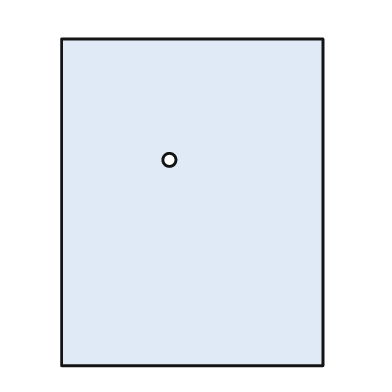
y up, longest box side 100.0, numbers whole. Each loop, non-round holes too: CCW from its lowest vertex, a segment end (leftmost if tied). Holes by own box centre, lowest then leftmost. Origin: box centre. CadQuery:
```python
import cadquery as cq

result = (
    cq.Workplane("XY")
    .moveTo(-40.0, -50.0)
    .lineTo(40.0, -50.0)
    .lineTo(40.0, 50.0)
    .lineTo(-40.0, 50.0)
    .close()
    .moveTo(-7.0, 13.0)
    .circle(2.0)
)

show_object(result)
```